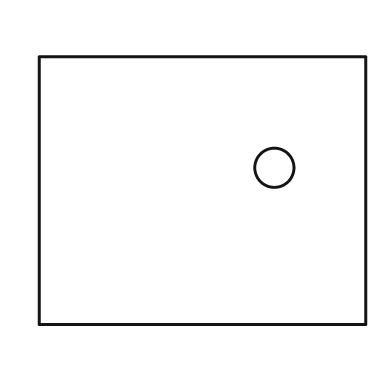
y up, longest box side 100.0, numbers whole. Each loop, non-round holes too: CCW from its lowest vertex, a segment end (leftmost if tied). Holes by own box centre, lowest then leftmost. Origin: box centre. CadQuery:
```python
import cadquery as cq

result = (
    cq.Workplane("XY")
    .moveTo(-50.0, -41.0)
    .lineTo(50.0, -41.0)
    .lineTo(50.0, 41.0)
    .lineTo(-50.0, 41.0)
    .close()
    .moveTo(22.0, 7.0)
    .circle(6.0)
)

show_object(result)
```